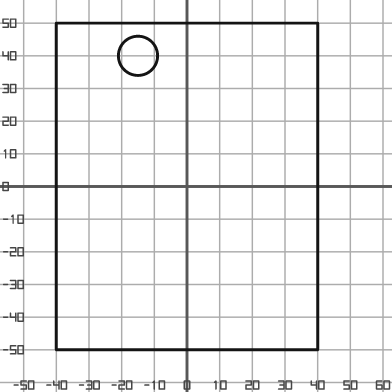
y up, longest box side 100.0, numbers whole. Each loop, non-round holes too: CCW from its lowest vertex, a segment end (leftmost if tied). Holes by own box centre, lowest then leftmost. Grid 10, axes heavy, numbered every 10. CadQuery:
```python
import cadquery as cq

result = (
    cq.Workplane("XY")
    .moveTo(-40.0, -50.0)
    .lineTo(40.0, -50.0)
    .lineTo(40.0, 50.0)
    .lineTo(-40.0, 50.0)
    .close()
    .moveTo(-15.0, 40.0)
    .circle(6.0)
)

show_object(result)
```